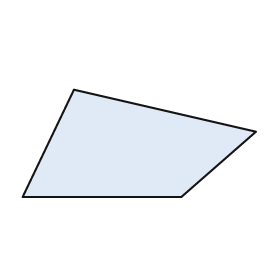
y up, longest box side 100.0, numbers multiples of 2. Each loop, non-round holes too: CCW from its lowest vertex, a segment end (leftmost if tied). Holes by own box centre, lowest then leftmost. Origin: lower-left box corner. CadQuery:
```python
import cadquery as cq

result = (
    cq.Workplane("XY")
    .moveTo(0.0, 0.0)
    .lineTo(68.0, 0.0)
    .lineTo(100.0, 28.0)
    .lineTo(22.0, 46.0)
    .close()
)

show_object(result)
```